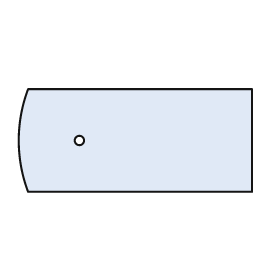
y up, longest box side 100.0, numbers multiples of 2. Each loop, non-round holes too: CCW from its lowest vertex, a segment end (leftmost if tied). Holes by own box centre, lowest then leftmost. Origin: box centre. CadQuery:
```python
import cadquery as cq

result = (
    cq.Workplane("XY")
    .moveTo(-46.0, -22.0)
    .lineTo(50.0, -22.0)
    .lineTo(50.0, 22.0)
    .lineTo(-46.0, 22.0)
    .threePointArc((-50.0, 0.0), (-46.0, -22.0))
    .close()
    .moveTo(-24.0, 0.0)
    .circle(2.0)
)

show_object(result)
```